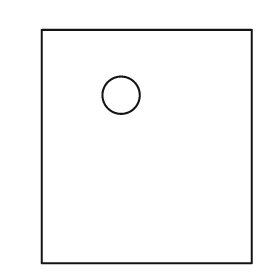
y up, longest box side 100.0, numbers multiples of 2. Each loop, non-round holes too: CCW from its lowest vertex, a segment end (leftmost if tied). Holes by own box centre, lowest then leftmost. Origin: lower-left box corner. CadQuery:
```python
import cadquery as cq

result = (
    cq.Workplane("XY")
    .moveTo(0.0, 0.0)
    .lineTo(90.0, 0.0)
    .lineTo(90.0, 100.0)
    .lineTo(0.0, 100.0)
    .close()
    .moveTo(34.0, 72.0)
    .circle(8.0)
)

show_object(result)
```